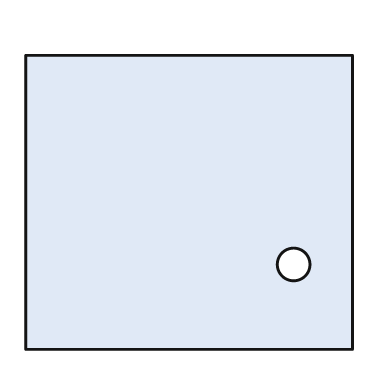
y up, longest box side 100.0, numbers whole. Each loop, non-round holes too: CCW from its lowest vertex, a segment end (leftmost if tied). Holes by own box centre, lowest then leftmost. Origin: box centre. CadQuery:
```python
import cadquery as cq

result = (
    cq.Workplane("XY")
    .moveTo(-50.0, -45.0)
    .lineTo(50.0, -45.0)
    .lineTo(50.0, 45.0)
    .lineTo(-50.0, 45.0)
    .close()
    .moveTo(32.0, -19.0)
    .circle(5.0)
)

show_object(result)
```